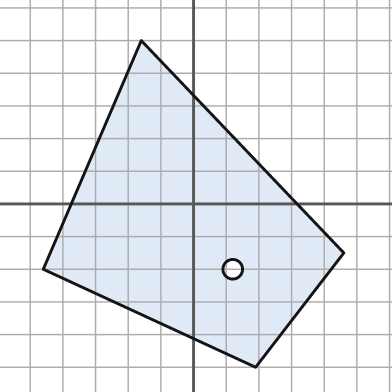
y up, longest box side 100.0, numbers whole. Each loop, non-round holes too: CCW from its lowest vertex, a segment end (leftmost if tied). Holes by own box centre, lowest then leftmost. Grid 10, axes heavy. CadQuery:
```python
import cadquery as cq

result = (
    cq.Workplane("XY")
    .moveTo(19.0, -50.0)
    .lineTo(46.0, -15.0)
    .lineTo(-16.0, 50.0)
    .lineTo(-46.0, -20.0)
    .close()
    .moveTo(12.0, -20.0)
    .circle(3.0)
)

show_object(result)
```